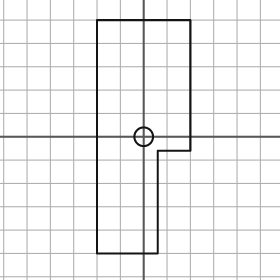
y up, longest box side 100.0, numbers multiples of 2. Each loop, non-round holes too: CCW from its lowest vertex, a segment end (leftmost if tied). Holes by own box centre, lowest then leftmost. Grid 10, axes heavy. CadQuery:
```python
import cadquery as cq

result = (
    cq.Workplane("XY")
    .moveTo(-20.0, -50.0)
    .lineTo(6.0, -50.0)
    .lineTo(6.0, -6.0)
    .lineTo(20.0, -6.0)
    .lineTo(20.0, 50.0)
    .lineTo(-20.0, 50.0)
    .close()
    .moveTo(0.0, 0.0)
    .circle(4.0)
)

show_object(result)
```